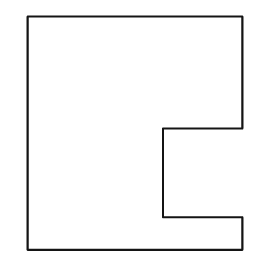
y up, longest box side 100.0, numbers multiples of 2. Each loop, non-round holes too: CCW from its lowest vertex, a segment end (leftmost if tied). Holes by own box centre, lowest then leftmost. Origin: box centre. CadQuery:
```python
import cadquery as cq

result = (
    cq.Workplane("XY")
    .moveTo(-46.0, -50.0)
    .lineTo(46.0, -50.0)
    .lineTo(46.0, -36.0)
    .lineTo(12.0, -36.0)
    .lineTo(12.0, 2.0)
    .lineTo(46.0, 2.0)
    .lineTo(46.0, 50.0)
    .lineTo(-46.0, 50.0)
    .close()
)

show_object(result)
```